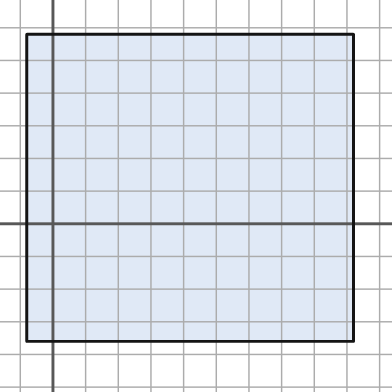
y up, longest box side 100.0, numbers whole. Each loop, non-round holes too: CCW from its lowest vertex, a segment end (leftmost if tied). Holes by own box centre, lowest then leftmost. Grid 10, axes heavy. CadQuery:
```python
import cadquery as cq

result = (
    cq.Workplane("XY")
    .moveTo(-8.0, -36.0)
    .lineTo(92.0, -36.0)
    .lineTo(92.0, 58.0)
    .lineTo(-8.0, 58.0)
    .close()
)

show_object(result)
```